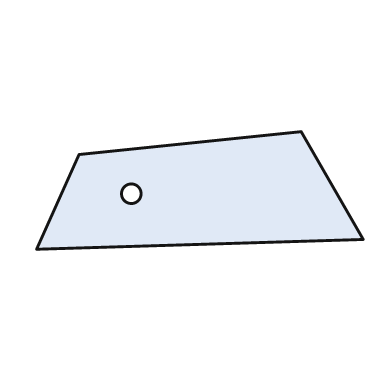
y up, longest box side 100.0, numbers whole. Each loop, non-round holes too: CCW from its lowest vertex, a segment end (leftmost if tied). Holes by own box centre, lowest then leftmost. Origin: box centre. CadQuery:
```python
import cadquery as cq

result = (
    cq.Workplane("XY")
    .moveTo(-50.0, -18.0)
    .lineTo(50.0, -15.0)
    .lineTo(31.0, 18.0)
    .lineTo(-37.0, 11.0)
    .close()
    .moveTo(-21.0, -1.0)
    .circle(3.0)
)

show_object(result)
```